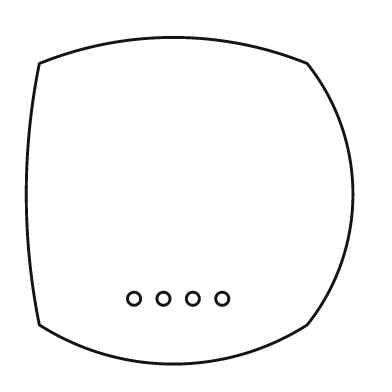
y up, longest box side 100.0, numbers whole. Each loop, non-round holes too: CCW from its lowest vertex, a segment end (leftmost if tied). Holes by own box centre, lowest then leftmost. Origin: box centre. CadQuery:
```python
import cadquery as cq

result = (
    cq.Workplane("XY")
    .moveTo(-46.0, -38.0)
    .threePointArc((-5.0, -50.0), (36.0, -38.0))
    .threePointArc((50.0, 2.0), (36.0, 42.0))
    .threePointArc((-5.0, 50.0), (-46.0, 42.0))
    .threePointArc((-50.0, 2.0), (-46.0, -38.0))
    .close()
    .moveTo(-17.0, -30.0)
    .circle(2.0)
    .moveTo(-8.0, -30.0)
    .circle(2.0)
    .moveTo(1.0, -30.0)
    .circle(2.0)
    .moveTo(10.0, -30.0)
    .circle(2.0)
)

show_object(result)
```